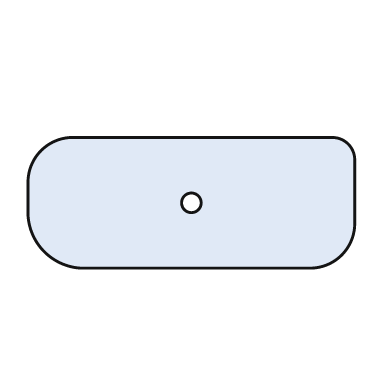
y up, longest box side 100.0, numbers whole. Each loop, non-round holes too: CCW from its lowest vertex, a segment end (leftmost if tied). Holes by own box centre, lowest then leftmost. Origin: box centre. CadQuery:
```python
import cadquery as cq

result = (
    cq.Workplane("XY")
    .moveTo(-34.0, -20.0)
    .lineTo(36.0, -20.0)
    .threePointArc((46.0, -16.0), (50.0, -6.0))
    .lineTo(50.0, 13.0)
    .threePointArc((48.0, 18.0), (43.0, 20.0))
    .lineTo(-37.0, 20.0)
    .threePointArc((-46.0, 16.0), (-50.0, 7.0))
    .lineTo(-50.0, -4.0)
    .threePointArc((-45.0, -15.0), (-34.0, -20.0))
    .close()
    .moveTo(0.0, 0.0)
    .circle(3.0)
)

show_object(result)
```